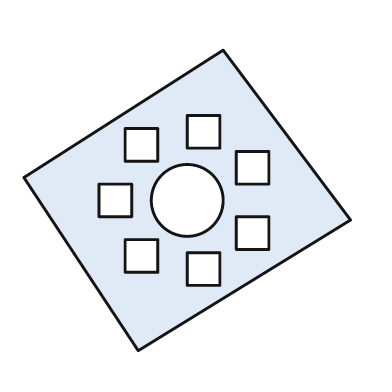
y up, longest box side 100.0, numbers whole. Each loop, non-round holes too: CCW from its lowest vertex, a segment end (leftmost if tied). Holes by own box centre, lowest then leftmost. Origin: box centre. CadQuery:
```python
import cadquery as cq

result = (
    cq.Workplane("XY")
    .moveTo(-15.0, -46.0)
    .lineTo(50.0, -6.0)
    .lineTo(11.0, 46.0)
    .lineTo(-50.0, 7.0)
    .close()
    .moveTo(0.0, -26.0)
    .lineTo(10.0, -26.0)
    .lineTo(10.0, -16.0)
    .lineTo(0.0, -16.0)
    .close()
    .moveTo(-19.0, -22.0)
    .lineTo(-9.0, -22.0)
    .lineTo(-9.0, -12.0)
    .lineTo(-19.0, -12.0)
    .close()
    .moveTo(15.0, -15.0)
    .lineTo(25.0, -15.0)
    .lineTo(25.0, -5.0)
    .lineTo(15.0, -5.0)
    .close()
    .moveTo(-27.0, -5.0)
    .lineTo(-17.0, -5.0)
    .lineTo(-17.0, 5.0)
    .lineTo(-27.0, 5.0)
    .close()
    .moveTo(0.0, 0.0)
    .circle(11.0)
    .moveTo(15.0, 5.0)
    .lineTo(25.0, 5.0)
    .lineTo(25.0, 15.0)
    .lineTo(15.0, 15.0)
    .close()
    .moveTo(-19.0, 12.0)
    .lineTo(-9.0, 12.0)
    .lineTo(-9.0, 22.0)
    .lineTo(-19.0, 22.0)
    .close()
    .moveTo(0.0, 16.0)
    .lineTo(10.0, 16.0)
    .lineTo(10.0, 26.0)
    .lineTo(0.0, 26.0)
    .close()
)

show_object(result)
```